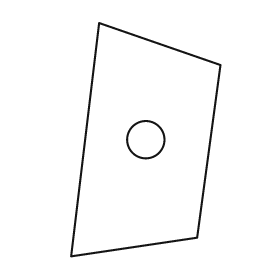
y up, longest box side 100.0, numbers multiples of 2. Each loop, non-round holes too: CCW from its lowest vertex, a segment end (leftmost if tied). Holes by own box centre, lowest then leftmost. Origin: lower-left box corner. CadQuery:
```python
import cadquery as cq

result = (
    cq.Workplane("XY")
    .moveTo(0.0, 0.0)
    .lineTo(54.0, 8.0)
    .lineTo(64.0, 82.0)
    .lineTo(12.0, 100.0)
    .close()
    .moveTo(32.0, 50.0)
    .circle(8.0)
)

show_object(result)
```